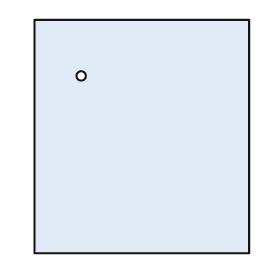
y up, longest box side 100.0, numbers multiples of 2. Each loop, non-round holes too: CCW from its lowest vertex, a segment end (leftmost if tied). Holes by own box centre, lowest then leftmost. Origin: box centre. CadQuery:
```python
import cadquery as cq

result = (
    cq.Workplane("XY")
    .moveTo(-46.0, -50.0)
    .lineTo(46.0, -50.0)
    .lineTo(46.0, 50.0)
    .lineTo(-46.0, 50.0)
    .close()
    .moveTo(-26.0, 26.0)
    .circle(2.0)
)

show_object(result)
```